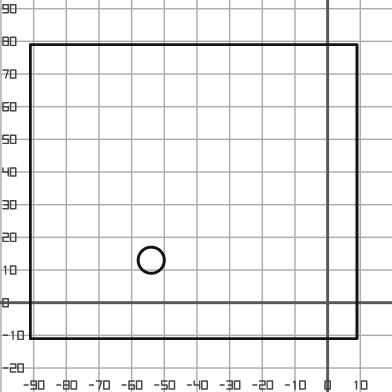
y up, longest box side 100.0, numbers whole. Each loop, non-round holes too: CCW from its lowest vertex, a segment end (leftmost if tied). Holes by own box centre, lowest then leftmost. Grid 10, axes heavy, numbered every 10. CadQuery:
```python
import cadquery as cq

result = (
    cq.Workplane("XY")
    .moveTo(-91.0, -11.0)
    .lineTo(9.0, -11.0)
    .lineTo(9.0, 79.0)
    .lineTo(-91.0, 79.0)
    .close()
    .moveTo(-54.0, 13.0)
    .circle(4.0)
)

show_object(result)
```